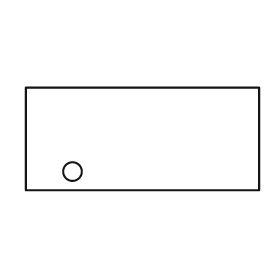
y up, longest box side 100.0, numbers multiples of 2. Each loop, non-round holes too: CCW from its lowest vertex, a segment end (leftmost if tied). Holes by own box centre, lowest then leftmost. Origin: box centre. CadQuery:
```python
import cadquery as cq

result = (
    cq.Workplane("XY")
    .moveTo(-50.0, -22.0)
    .lineTo(50.0, -22.0)
    .lineTo(50.0, 22.0)
    .lineTo(-50.0, 22.0)
    .close()
    .moveTo(-30.0, -14.0)
    .circle(4.0)
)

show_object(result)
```